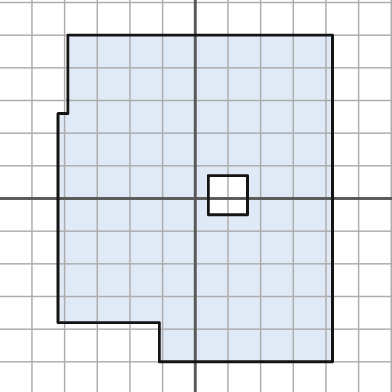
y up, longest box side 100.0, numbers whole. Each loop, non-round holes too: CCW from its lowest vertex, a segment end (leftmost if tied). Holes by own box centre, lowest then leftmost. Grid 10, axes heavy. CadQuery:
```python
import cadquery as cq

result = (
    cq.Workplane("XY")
    .moveTo(-11.0, -50.0)
    .lineTo(42.0, -50.0)
    .lineTo(42.0, 50.0)
    .lineTo(-39.0, 50.0)
    .lineTo(-39.0, 26.0)
    .lineTo(-42.0, 26.0)
    .lineTo(-42.0, -38.0)
    .lineTo(-11.0, -38.0)
    .close()
    .moveTo(4.0, -5.0)
    .lineTo(16.0, -5.0)
    .lineTo(16.0, 7.0)
    .lineTo(4.0, 7.0)
    .close()
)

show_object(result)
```